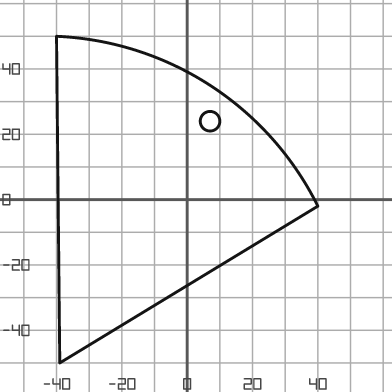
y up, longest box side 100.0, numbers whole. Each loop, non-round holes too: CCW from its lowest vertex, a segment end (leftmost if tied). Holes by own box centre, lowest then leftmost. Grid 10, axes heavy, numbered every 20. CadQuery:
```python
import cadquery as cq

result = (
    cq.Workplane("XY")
    .moveTo(-39.0, -50.0)
    .lineTo(40.0, -2.0)
    .threePointArc((7.0, 35.0), (-40.0, 50.0))
    .close()
    .moveTo(7.0, 24.0)
    .circle(3.0)
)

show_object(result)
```